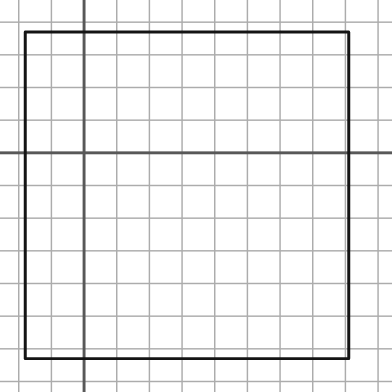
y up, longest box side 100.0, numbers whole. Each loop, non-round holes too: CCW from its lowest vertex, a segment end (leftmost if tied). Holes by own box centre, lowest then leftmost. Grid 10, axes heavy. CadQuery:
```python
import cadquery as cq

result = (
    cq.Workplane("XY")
    .moveTo(-18.0, -63.0)
    .lineTo(81.0, -63.0)
    .lineTo(81.0, 37.0)
    .lineTo(-18.0, 37.0)
    .close()
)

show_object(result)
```